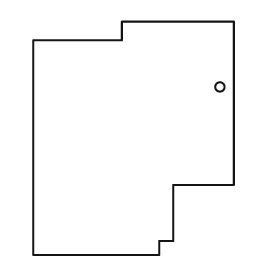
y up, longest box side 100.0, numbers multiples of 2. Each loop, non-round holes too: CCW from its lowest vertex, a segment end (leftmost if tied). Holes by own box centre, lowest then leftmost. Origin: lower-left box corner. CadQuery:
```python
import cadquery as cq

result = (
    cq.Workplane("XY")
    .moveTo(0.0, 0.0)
    .lineTo(54.0, 0.0)
    .lineTo(54.0, 6.0)
    .lineTo(60.0, 6.0)
    .lineTo(60.0, 30.0)
    .lineTo(86.0, 30.0)
    .lineTo(86.0, 100.0)
    .lineTo(38.0, 100.0)
    .lineTo(38.0, 92.0)
    .lineTo(0.0, 92.0)
    .close()
    .moveTo(80.0, 72.0)
    .circle(2.0)
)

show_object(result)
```